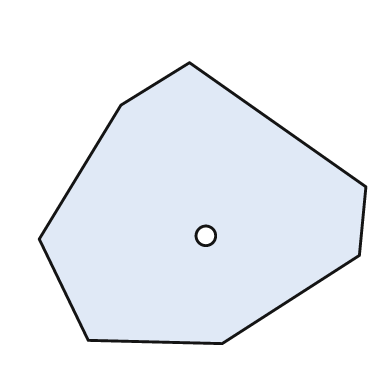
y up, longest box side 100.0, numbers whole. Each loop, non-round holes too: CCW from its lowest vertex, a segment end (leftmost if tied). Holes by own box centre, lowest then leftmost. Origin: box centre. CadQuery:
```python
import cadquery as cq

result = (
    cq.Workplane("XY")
    .moveTo(6.0, -43.0)
    .lineTo(48.0, -16.0)
    .lineTo(50.0, 5.0)
    .lineTo(-4.0, 43.0)
    .lineTo(-25.0, 30.0)
    .lineTo(-50.0, -11.0)
    .lineTo(-35.0, -42.0)
    .close()
    .moveTo(1.0, -10.0)
    .circle(3.0)
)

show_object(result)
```